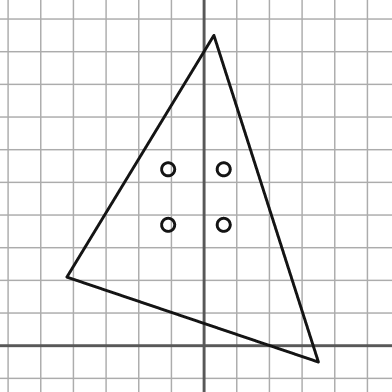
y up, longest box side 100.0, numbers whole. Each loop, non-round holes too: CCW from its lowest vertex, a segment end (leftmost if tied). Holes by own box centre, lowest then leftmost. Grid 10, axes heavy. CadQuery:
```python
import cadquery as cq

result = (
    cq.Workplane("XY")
    .moveTo(35.0, -5.0)
    .lineTo(3.0, 95.0)
    .lineTo(-42.0, 21.0)
    .close()
    .moveTo(-11.0, 37.0)
    .circle(2.0)
    .moveTo(6.0, 37.0)
    .circle(2.0)
    .moveTo(-11.0, 54.0)
    .circle(2.0)
    .moveTo(6.0, 54.0)
    .circle(2.0)
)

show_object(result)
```